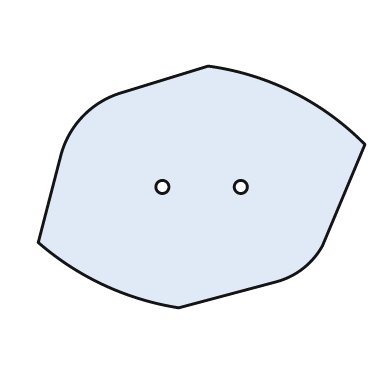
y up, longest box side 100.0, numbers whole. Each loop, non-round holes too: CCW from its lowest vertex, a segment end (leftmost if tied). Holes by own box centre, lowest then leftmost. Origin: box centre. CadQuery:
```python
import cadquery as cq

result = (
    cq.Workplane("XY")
    .moveTo(-7.0, -37.0)
    .lineTo(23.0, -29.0)
    .threePointArc((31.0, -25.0), (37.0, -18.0))
    .lineTo(50.0, 13.0)
    .threePointArc((28.0, 29.0), (2.0, 37.0))
    .lineTo(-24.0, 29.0)
    .threePointArc((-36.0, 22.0), (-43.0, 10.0))
    .lineTo(-50.0, -17.0)
    .threePointArc((-30.0, -30.0), (-7.0, -37.0))
    .close()
    .moveTo(-12.0, 0.0)
    .circle(2.0)
    .moveTo(12.0, 0.0)
    .circle(2.0)
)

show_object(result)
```